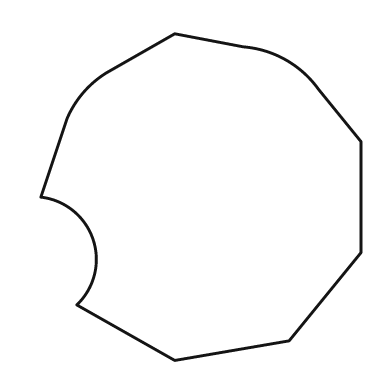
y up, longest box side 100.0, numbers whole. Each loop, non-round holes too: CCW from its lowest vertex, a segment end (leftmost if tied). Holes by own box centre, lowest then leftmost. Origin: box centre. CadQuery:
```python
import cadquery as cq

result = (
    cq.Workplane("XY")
    .moveTo(-8.0, -50.0)
    .lineTo(27.0, -44.0)
    .lineTo(49.0, -17.0)
    .lineTo(49.0, 17.0)
    .lineTo(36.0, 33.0)
    .threePointArc((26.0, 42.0), (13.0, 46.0))
    .lineTo(-8.0, 50.0)
    .lineTo(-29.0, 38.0)
    .threePointArc((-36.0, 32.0), (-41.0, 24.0))
    .lineTo(-49.0, 0.0)
    .threePointArc((-33.0, -13.0), (-38.0, -33.0))
    .close()
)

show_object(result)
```